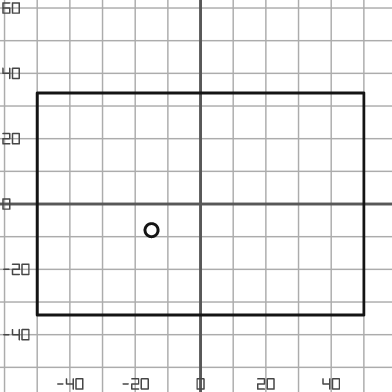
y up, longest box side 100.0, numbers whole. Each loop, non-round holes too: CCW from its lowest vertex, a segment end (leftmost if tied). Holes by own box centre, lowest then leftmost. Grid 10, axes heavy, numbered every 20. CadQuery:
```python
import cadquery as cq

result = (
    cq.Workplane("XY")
    .moveTo(-50.0, -34.0)
    .lineTo(50.0, -34.0)
    .lineTo(50.0, 34.0)
    .lineTo(-50.0, 34.0)
    .close()
    .moveTo(-15.0, -8.0)
    .circle(2.0)
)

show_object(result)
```